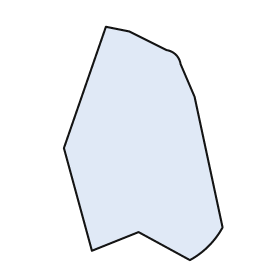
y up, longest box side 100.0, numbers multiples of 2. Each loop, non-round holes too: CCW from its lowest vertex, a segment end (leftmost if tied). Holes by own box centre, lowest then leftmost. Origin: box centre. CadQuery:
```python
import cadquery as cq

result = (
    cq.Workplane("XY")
    .moveTo(20.0, -50.0)
    .threePointArc((28.0, -44.0), (34.0, -36.0))
    .lineTo(22.0, 20.0)
    .lineTo(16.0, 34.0)
    .threePointArc((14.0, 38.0), (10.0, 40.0))
    .lineTo(-6.0, 48.0)
    .lineTo(-16.0, 50.0)
    .lineTo(-34.0, -2.0)
    .lineTo(-22.0, -46.0)
    .lineTo(-2.0, -38.0)
    .close()
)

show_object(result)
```